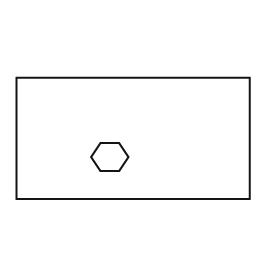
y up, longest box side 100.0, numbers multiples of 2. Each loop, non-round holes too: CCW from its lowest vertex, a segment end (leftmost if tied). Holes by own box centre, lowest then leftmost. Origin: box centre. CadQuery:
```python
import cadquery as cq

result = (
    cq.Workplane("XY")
    .moveTo(-50.0, -26.0)
    .lineTo(50.0, -26.0)
    .lineTo(50.0, 26.0)
    .lineTo(-50.0, 26.0)
    .close()
    .moveTo(-14.0, -14.0)
    .lineTo(-6.0, -14.0)
    .lineTo(-2.0, -8.0)
    .lineTo(-6.0, -2.0)
    .lineTo(-14.0, -2.0)
    .lineTo(-18.0, -8.0)
    .close()
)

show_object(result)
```